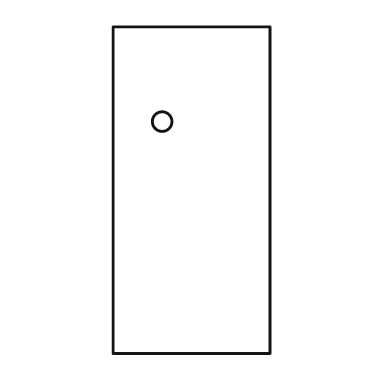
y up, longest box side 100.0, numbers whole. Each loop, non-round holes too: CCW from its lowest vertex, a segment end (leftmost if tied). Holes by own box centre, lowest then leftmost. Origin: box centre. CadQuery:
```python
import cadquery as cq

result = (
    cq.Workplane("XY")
    .moveTo(-24.0, -50.0)
    .lineTo(24.0, -50.0)
    .lineTo(24.0, 50.0)
    .lineTo(-24.0, 50.0)
    .close()
    .moveTo(-9.0, 21.0)
    .circle(3.0)
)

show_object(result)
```